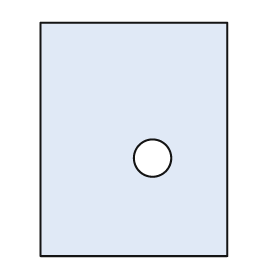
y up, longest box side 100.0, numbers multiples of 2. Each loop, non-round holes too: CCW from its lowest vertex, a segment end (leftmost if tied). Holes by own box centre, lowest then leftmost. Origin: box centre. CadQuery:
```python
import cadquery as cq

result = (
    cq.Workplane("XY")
    .moveTo(-40.0, -50.0)
    .lineTo(40.0, -50.0)
    .lineTo(40.0, 50.0)
    .lineTo(-40.0, 50.0)
    .close()
    .moveTo(8.0, -8.0)
    .circle(8.0)
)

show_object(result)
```